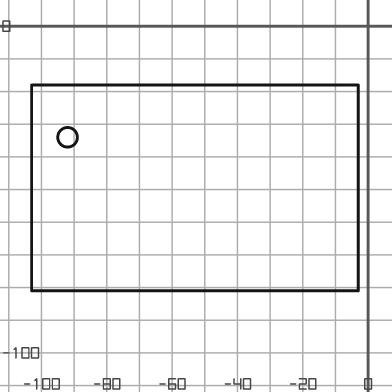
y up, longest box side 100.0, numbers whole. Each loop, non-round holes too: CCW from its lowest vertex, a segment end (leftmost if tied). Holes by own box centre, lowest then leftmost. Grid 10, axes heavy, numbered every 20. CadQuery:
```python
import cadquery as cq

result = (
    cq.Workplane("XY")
    .moveTo(-103.0, -81.0)
    .lineTo(-3.0, -81.0)
    .lineTo(-3.0, -18.0)
    .lineTo(-103.0, -18.0)
    .close()
    .moveTo(-92.0, -34.0)
    .circle(3.0)
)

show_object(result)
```